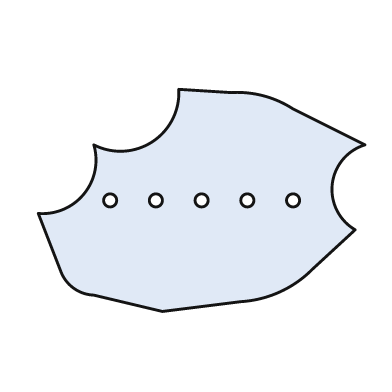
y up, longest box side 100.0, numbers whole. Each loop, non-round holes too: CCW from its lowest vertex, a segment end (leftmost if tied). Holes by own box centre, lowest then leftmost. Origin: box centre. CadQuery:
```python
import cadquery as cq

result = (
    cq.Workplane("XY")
    .moveTo(-12.0, -34.0)
    .lineTo(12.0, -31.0)
    .threePointArc((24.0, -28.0), (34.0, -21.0))
    .lineTo(47.0, -9.0)
    .threePointArc((40.0, 5.0), (50.0, 17.0))
    .lineTo(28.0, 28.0)
    .threePointArc((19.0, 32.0), (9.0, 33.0))
    .lineTo(-7.0, 34.0)
    .threePointArc((-15.0, 18.0), (-33.0, 17.0))
    .threePointArc((-36.0, 2.0), (-50.0, -4.0))
    .lineTo(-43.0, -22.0)
    .threePointArc((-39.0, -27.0), (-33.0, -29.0))
    .close()
    .moveTo(-28.0, 0.0)
    .circle(2.0)
    .moveTo(-14.0, 0.0)
    .circle(2.0)
    .moveTo(0.0, 0.0)
    .circle(2.0)
    .moveTo(14.0, 0.0)
    .circle(2.0)
    .moveTo(28.0, 0.0)
    .circle(2.0)
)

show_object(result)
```